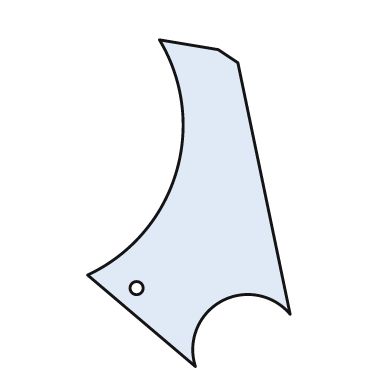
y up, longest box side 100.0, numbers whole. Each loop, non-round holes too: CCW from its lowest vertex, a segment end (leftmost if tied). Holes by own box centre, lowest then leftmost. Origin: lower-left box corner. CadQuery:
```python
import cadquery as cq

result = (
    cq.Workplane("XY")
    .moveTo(33.0, 0.0)
    .threePointArc((41.0, 20.0), (62.0, 16.0))
    .lineTo(46.0, 93.0)
    .lineTo(40.0, 97.0)
    .lineTo(22.0, 100.0)
    .threePointArc((27.0, 59.0), (0.0, 28.0))
    .close()
    .moveTo(15.0, 24.0)
    .circle(2.0)
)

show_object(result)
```